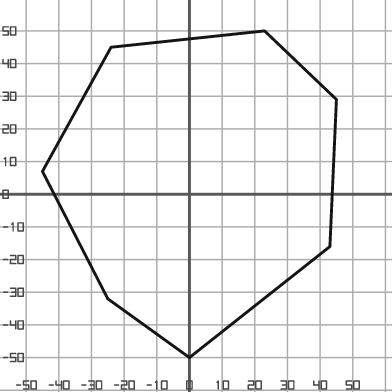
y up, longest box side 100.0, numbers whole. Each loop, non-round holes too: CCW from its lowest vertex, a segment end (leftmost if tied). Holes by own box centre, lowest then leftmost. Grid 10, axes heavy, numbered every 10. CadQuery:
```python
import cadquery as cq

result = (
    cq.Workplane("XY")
    .moveTo(0.0, -50.0)
    .lineTo(43.0, -16.0)
    .lineTo(45.0, 29.0)
    .lineTo(23.0, 50.0)
    .lineTo(-24.0, 45.0)
    .lineTo(-45.0, 7.0)
    .lineTo(-25.0, -32.0)
    .close()
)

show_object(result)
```